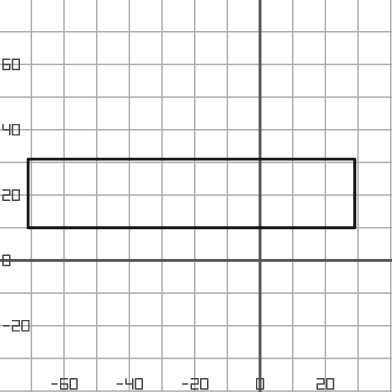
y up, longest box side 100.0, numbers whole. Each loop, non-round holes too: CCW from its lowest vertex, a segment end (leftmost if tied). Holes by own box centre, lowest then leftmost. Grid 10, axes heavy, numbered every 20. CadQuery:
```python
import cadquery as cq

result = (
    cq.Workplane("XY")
    .moveTo(-71.0, 10.0)
    .lineTo(29.0, 10.0)
    .lineTo(29.0, 31.0)
    .lineTo(-71.0, 31.0)
    .close()
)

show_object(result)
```